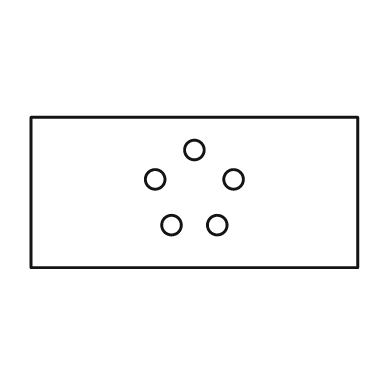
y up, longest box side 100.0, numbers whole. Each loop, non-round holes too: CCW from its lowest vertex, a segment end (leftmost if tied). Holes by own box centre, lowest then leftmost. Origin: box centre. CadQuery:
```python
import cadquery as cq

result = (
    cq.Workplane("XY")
    .moveTo(-50.0, -23.0)
    .lineTo(50.0, -23.0)
    .lineTo(50.0, 23.0)
    .lineTo(-50.0, 23.0)
    .close()
    .moveTo(-7.0, -10.0)
    .circle(3.0)
    .moveTo(7.0, -10.0)
    .circle(3.0)
    .moveTo(-12.0, 4.0)
    .circle(3.0)
    .moveTo(12.0, 4.0)
    .circle(3.0)
    .moveTo(0.0, 13.0)
    .circle(3.0)
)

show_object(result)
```